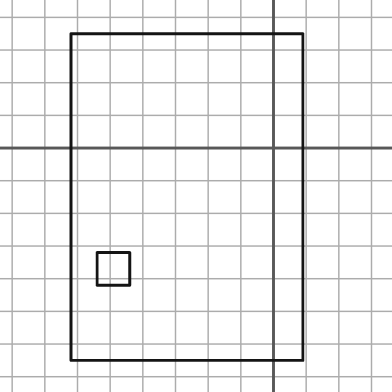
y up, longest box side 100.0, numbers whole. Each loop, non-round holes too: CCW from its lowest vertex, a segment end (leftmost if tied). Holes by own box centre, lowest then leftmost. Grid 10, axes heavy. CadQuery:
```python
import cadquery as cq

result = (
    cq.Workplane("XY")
    .moveTo(-62.0, -65.0)
    .lineTo(9.0, -65.0)
    .lineTo(9.0, 35.0)
    .lineTo(-62.0, 35.0)
    .close()
    .moveTo(-54.0, -42.0)
    .lineTo(-44.0, -42.0)
    .lineTo(-44.0, -32.0)
    .lineTo(-54.0, -32.0)
    .close()
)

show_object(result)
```